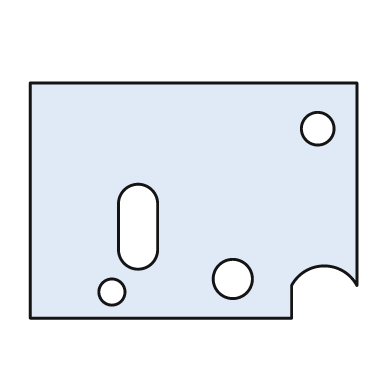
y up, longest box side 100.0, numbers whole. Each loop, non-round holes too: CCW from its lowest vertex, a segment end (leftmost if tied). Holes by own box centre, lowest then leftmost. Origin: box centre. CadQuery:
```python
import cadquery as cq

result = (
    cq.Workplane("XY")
    .moveTo(-50.0, -36.0)
    .lineTo(30.0, -36.0)
    .lineTo(30.0, -26.0)
    .threePointArc((40.0, -20.0), (50.0, -26.0))
    .lineTo(50.0, 36.0)
    .lineTo(-50.0, 36.0)
    .close()
    .moveTo(-25.0, -28.0)
    .circle(4.0)
    .moveTo(12.0, -24.0)
    .circle(6.0)
    .moveTo(-23.0, -15.0)
    .threePointArc((-17.0, -21.0), (-11.0, -15.0))
    .lineTo(-11.0, -1.0)
    .threePointArc((-17.0, 5.0), (-23.0, -1.0))
    .close()
    .moveTo(38.0, 22.0)
    .circle(5.0)
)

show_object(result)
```